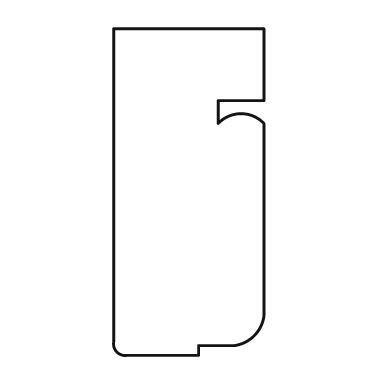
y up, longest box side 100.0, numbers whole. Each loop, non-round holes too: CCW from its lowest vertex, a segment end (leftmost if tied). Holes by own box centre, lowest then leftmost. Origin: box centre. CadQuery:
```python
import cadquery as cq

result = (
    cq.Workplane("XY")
    .moveTo(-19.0, -50.0)
    .lineTo(3.0, -50.0)
    .lineTo(3.0, -47.0)
    .lineTo(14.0, -47.0)
    .threePointArc((20.0, -44.0), (23.0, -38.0))
    .lineTo(23.0, 21.0)
    .threePointArc((16.0, 24.0), (9.0, 21.0))
    .lineTo(9.0, 28.0)
    .lineTo(23.0, 28.0)
    .lineTo(23.0, 50.0)
    .lineTo(-23.0, 50.0)
    .lineTo(-23.0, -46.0)
    .threePointArc((-22.0, -49.0), (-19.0, -50.0))
    .close()
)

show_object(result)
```